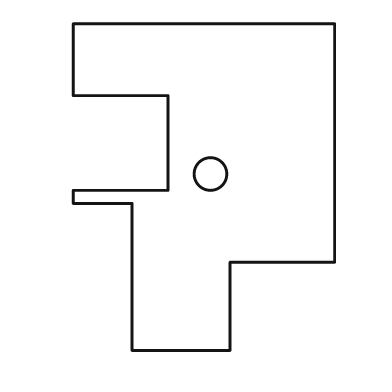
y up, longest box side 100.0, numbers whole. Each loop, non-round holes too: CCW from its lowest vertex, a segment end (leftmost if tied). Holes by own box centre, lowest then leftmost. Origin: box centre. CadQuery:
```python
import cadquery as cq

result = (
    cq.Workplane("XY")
    .moveTo(-22.0, -50.0)
    .lineTo(8.0, -50.0)
    .lineTo(8.0, -23.0)
    .lineTo(40.0, -23.0)
    .lineTo(40.0, 50.0)
    .lineTo(-40.0, 50.0)
    .lineTo(-40.0, 28.0)
    .lineTo(-11.0, 28.0)
    .lineTo(-11.0, -1.0)
    .lineTo(-40.0, -1.0)
    .lineTo(-40.0, -5.0)
    .lineTo(-22.0, -5.0)
    .close()
    .moveTo(2.0, 4.0)
    .circle(5.0)
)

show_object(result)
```